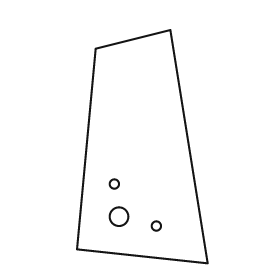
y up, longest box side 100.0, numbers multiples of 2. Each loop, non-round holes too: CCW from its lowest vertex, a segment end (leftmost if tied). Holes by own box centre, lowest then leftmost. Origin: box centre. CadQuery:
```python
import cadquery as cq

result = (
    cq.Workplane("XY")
    .moveTo(28.0, -50.0)
    .lineTo(12.0, 50.0)
    .lineTo(-20.0, 42.0)
    .lineTo(-28.0, -44.0)
    .close()
    .moveTo(6.0, -34.0)
    .circle(2.0)
    .moveTo(-10.0, -30.0)
    .circle(4.0)
    .moveTo(-12.0, -16.0)
    .circle(2.0)
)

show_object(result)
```